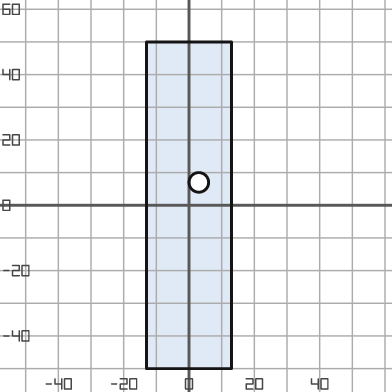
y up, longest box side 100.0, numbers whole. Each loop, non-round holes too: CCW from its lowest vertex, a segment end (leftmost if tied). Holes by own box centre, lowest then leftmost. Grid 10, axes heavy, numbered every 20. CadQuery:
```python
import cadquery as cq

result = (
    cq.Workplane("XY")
    .moveTo(-13.0, -50.0)
    .lineTo(13.0, -50.0)
    .lineTo(13.0, 50.0)
    .lineTo(-13.0, 50.0)
    .close()
    .moveTo(3.0, 7.0)
    .circle(3.0)
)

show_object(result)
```